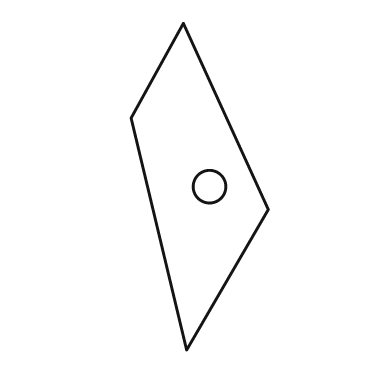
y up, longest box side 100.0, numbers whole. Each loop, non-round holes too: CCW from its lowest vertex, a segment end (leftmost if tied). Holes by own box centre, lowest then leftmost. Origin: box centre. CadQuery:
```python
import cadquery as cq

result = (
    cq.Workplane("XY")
    .moveTo(-4.0, -50.0)
    .lineTo(21.0, -7.0)
    .lineTo(-5.0, 50.0)
    .lineTo(-21.0, 21.0)
    .close()
    .moveTo(3.0, 0.0)
    .circle(5.0)
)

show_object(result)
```